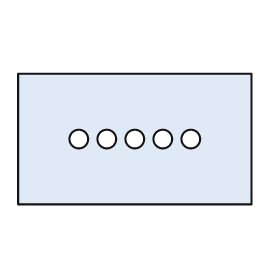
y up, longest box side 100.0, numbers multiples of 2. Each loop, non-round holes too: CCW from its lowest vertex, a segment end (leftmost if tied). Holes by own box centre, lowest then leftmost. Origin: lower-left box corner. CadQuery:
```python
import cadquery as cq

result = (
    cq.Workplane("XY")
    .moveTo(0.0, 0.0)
    .lineTo(100.0, 0.0)
    .lineTo(100.0, 56.0)
    .lineTo(0.0, 56.0)
    .close()
    .moveTo(26.0, 28.0)
    .circle(4.0)
    .moveTo(38.0, 28.0)
    .circle(4.0)
    .moveTo(50.0, 28.0)
    .circle(4.0)
    .moveTo(62.0, 28.0)
    .circle(4.0)
    .moveTo(74.0, 28.0)
    .circle(4.0)
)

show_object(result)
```